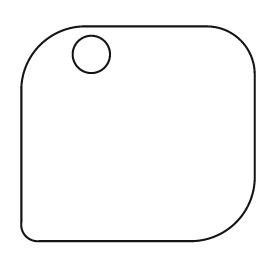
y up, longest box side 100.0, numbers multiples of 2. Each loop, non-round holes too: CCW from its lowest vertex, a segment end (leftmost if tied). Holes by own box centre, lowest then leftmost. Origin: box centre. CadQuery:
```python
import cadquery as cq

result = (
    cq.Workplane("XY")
    .moveTo(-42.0, -46.0)
    .lineTo(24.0, -46.0)
    .threePointArc((42.0, -38.0), (50.0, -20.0))
    .lineTo(50.0, 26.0)
    .threePointArc((44.0, 40.0), (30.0, 46.0))
    .lineTo(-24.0, 46.0)
    .threePointArc((-42.0, 38.0), (-50.0, 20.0))
    .lineTo(-50.0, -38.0)
    .threePointArc((-48.0, -44.0), (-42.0, -46.0))
    .close()
    .moveTo(-20.0, 34.0)
    .circle(8.0)
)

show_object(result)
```